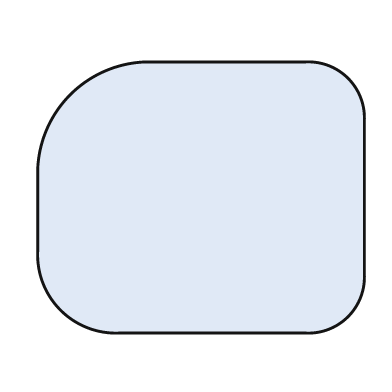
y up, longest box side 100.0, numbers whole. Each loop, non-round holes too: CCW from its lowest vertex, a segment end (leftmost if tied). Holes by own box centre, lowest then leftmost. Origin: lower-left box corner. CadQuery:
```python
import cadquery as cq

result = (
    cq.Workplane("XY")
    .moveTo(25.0, 0.0)
    .lineTo(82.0, 0.0)
    .threePointArc((95.0, 5.0), (100.0, 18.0))
    .lineTo(100.0, 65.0)
    .threePointArc((95.0, 78.0), (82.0, 83.0))
    .lineTo(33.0, 83.0)
    .threePointArc((10.0, 73.0), (0.0, 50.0))
    .lineTo(0.0, 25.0)
    .threePointArc((7.0, 7.0), (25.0, 0.0))
    .close()
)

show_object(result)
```